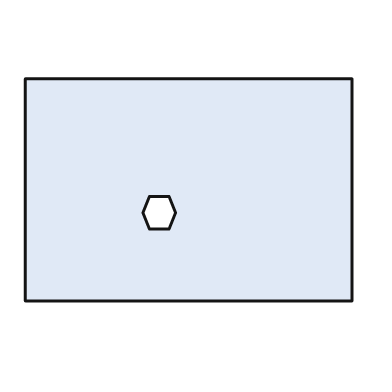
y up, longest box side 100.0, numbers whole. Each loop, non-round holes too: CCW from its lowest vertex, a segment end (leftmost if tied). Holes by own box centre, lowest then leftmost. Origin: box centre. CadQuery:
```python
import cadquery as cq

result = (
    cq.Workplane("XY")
    .moveTo(-50.0, -34.0)
    .lineTo(50.0, -34.0)
    .lineTo(50.0, 34.0)
    .lineTo(-50.0, 34.0)
    .close()
    .moveTo(-12.0, -12.0)
    .lineTo(-6.0, -12.0)
    .lineTo(-4.0, -7.0)
    .lineTo(-6.0, -2.0)
    .lineTo(-12.0, -2.0)
    .lineTo(-14.0, -7.0)
    .close()
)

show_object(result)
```